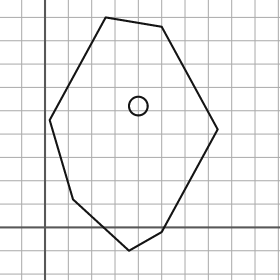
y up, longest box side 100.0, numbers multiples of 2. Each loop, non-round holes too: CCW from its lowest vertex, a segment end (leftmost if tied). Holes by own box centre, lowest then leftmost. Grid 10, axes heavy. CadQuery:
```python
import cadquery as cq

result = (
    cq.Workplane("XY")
    .moveTo(36.0, -10.0)
    .lineTo(50.0, -2.0)
    .lineTo(74.0, 42.0)
    .lineTo(50.0, 86.0)
    .lineTo(26.0, 90.0)
    .lineTo(2.0, 46.0)
    .lineTo(12.0, 12.0)
    .close()
    .moveTo(40.0, 52.0)
    .circle(4.0)
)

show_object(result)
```